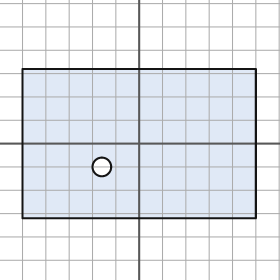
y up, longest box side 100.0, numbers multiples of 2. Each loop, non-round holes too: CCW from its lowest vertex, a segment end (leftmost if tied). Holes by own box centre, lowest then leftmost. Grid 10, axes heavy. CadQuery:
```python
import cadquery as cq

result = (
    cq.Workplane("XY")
    .moveTo(-50.0, -32.0)
    .lineTo(50.0, -32.0)
    .lineTo(50.0, 32.0)
    .lineTo(-50.0, 32.0)
    .close()
    .moveTo(-16.0, -10.0)
    .circle(4.0)
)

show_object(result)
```